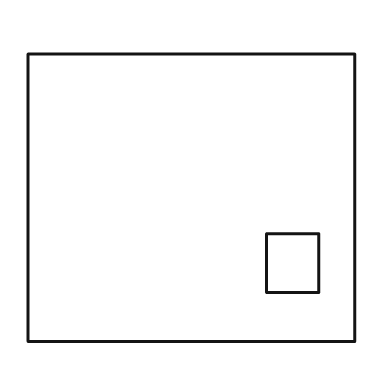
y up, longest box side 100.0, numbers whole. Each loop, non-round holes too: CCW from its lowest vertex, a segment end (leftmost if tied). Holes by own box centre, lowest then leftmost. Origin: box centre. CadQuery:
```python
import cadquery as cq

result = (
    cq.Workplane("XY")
    .moveTo(-50.0, -44.0)
    .lineTo(50.0, -44.0)
    .lineTo(50.0, 44.0)
    .lineTo(-50.0, 44.0)
    .close()
    .moveTo(23.0, -29.0)
    .lineTo(39.0, -29.0)
    .lineTo(39.0, -11.0)
    .lineTo(23.0, -11.0)
    .close()
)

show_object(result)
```